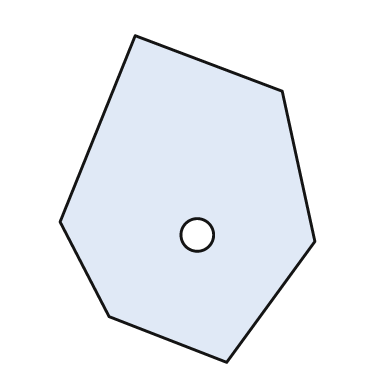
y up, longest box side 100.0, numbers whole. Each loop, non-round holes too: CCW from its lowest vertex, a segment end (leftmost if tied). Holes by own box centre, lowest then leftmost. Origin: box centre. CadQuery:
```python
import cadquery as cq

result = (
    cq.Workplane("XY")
    .moveTo(12.0, -50.0)
    .lineTo(39.0, -13.0)
    .lineTo(29.0, 33.0)
    .lineTo(-16.0, 50.0)
    .lineTo(-39.0, -7.0)
    .lineTo(-24.0, -36.0)
    .close()
    .moveTo(3.0, -11.0)
    .circle(5.0)
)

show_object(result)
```